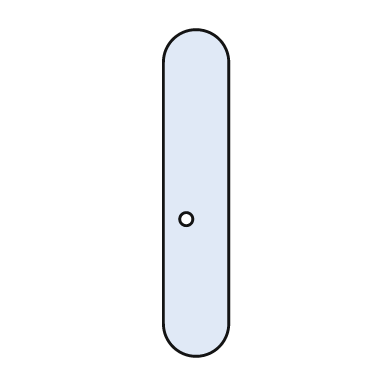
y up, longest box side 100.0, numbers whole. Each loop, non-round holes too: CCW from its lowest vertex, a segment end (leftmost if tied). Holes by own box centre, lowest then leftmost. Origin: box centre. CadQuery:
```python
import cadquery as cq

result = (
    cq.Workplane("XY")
    .moveTo(-10.0, -40.0)
    .threePointArc((0.0, -50.0), (10.0, -40.0))
    .lineTo(10.0, 40.0)
    .threePointArc((0.0, 50.0), (-10.0, 40.0))
    .close()
    .moveTo(-3.0, -8.0)
    .circle(2.0)
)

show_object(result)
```